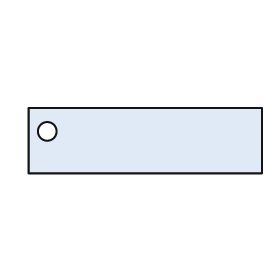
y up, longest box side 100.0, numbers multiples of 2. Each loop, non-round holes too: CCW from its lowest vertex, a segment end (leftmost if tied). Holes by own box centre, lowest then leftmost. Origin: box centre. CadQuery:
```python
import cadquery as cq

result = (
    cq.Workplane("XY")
    .moveTo(-50.0, -14.0)
    .lineTo(50.0, -14.0)
    .lineTo(50.0, 14.0)
    .lineTo(-50.0, 14.0)
    .close()
    .moveTo(-42.0, 4.0)
    .circle(4.0)
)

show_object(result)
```